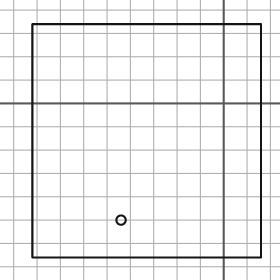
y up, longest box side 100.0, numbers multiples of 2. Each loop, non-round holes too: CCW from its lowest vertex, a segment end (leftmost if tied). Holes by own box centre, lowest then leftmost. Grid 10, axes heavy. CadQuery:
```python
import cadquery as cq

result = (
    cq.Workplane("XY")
    .moveTo(-82.0, -66.0)
    .lineTo(16.0, -66.0)
    .lineTo(16.0, 34.0)
    .lineTo(-82.0, 34.0)
    .close()
    .moveTo(-44.0, -50.0)
    .circle(2.0)
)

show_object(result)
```